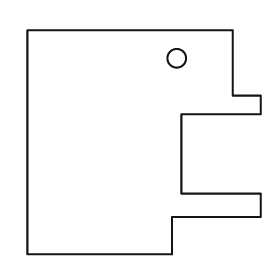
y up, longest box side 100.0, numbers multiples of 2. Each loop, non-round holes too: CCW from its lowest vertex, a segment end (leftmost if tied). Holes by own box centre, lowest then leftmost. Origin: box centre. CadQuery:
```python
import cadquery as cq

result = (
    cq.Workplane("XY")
    .moveTo(-50.0, -48.0)
    .lineTo(12.0, -48.0)
    .lineTo(12.0, -32.0)
    .lineTo(50.0, -32.0)
    .lineTo(50.0, -22.0)
    .lineTo(16.0, -22.0)
    .lineTo(16.0, 12.0)
    .lineTo(50.0, 12.0)
    .lineTo(50.0, 20.0)
    .lineTo(38.0, 20.0)
    .lineTo(38.0, 48.0)
    .lineTo(-50.0, 48.0)
    .close()
    .moveTo(14.0, 36.0)
    .circle(4.0)
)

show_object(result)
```